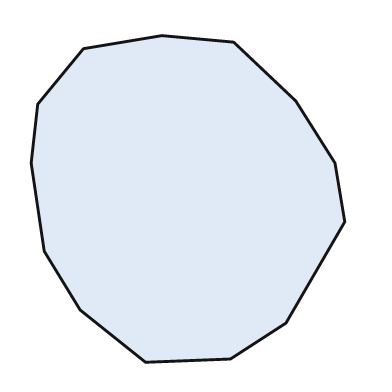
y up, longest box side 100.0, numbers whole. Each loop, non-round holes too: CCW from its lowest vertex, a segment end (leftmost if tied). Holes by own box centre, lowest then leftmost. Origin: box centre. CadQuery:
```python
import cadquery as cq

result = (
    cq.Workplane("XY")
    .moveTo(-13.0, -50.0)
    .lineTo(13.0, -49.0)
    .lineTo(30.0, -38.0)
    .lineTo(48.0, -7.0)
    .lineTo(45.0, 11.0)
    .lineTo(33.0, 30.0)
    .lineTo(14.0, 48.0)
    .lineTo(-8.0, 50.0)
    .lineTo(-32.0, 46.0)
    .lineTo(-46.0, 29.0)
    .lineTo(-48.0, 11.0)
    .lineTo(-44.0, -16.0)
    .lineTo(-33.0, -34.0)
    .close()
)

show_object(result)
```